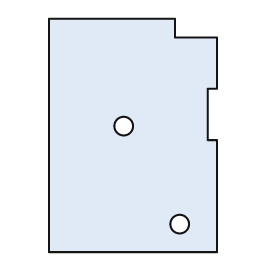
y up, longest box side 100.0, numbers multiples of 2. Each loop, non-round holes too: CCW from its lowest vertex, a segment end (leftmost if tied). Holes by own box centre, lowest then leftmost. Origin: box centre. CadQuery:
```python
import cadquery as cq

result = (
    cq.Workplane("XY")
    .moveTo(-36.0, -50.0)
    .lineTo(36.0, -50.0)
    .lineTo(36.0, -2.0)
    .lineTo(32.0, -2.0)
    .lineTo(32.0, 20.0)
    .lineTo(36.0, 20.0)
    .lineTo(36.0, 42.0)
    .lineTo(18.0, 42.0)
    .lineTo(18.0, 50.0)
    .lineTo(-36.0, 50.0)
    .close()
    .moveTo(20.0, -38.0)
    .circle(4.0)
    .moveTo(-4.0, 4.0)
    .circle(4.0)
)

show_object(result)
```